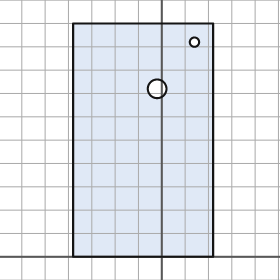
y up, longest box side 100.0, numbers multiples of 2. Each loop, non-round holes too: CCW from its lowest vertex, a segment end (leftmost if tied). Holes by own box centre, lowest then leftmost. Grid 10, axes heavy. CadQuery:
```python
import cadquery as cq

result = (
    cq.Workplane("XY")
    .moveTo(-38.0, 0.0)
    .lineTo(22.0, 0.0)
    .lineTo(22.0, 100.0)
    .lineTo(-38.0, 100.0)
    .close()
    .moveTo(-2.0, 72.0)
    .circle(4.0)
    .moveTo(14.0, 92.0)
    .circle(2.0)
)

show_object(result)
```